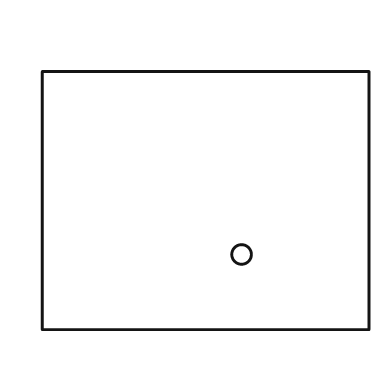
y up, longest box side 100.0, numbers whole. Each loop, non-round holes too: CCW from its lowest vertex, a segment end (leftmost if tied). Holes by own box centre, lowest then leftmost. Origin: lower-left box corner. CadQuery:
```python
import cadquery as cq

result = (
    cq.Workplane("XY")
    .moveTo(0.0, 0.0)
    .lineTo(100.0, 0.0)
    .lineTo(100.0, 79.0)
    .lineTo(0.0, 79.0)
    .close()
    .moveTo(61.0, 23.0)
    .circle(3.0)
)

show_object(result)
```